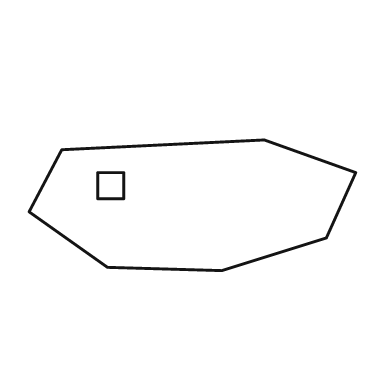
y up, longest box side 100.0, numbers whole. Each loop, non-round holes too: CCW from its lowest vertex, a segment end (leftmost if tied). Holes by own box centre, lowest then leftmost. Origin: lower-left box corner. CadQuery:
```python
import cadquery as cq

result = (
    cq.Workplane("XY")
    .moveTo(59.0, 0.0)
    .lineTo(91.0, 10.0)
    .lineTo(100.0, 30.0)
    .lineTo(72.0, 40.0)
    .lineTo(10.0, 37.0)
    .lineTo(0.0, 18.0)
    .lineTo(24.0, 1.0)
    .close()
    .moveTo(21.0, 22.0)
    .lineTo(29.0, 22.0)
    .lineTo(29.0, 30.0)
    .lineTo(21.0, 30.0)
    .close()
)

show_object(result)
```